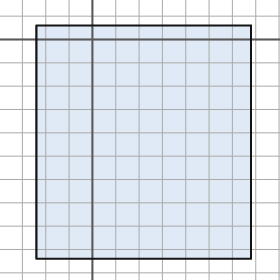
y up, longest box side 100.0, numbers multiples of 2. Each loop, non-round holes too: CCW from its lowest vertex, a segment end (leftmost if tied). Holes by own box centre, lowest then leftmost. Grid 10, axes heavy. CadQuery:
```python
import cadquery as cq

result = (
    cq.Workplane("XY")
    .moveTo(-24.0, -94.0)
    .lineTo(68.0, -94.0)
    .lineTo(68.0, 6.0)
    .lineTo(-24.0, 6.0)
    .close()
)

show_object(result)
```